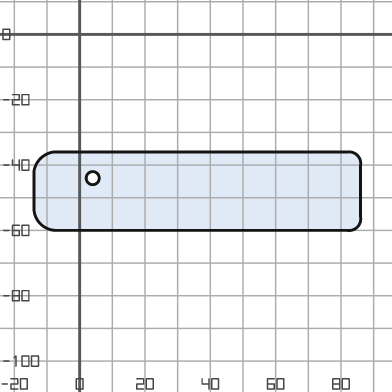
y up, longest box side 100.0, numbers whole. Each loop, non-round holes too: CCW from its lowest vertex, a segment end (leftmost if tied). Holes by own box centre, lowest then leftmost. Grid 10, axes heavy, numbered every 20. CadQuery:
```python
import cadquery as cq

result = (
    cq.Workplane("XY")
    .moveTo(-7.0, -60.0)
    .lineTo(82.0, -60.0)
    .threePointArc((85.0, -59.0), (86.0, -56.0))
    .lineTo(86.0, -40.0)
    .threePointArc((85.0, -37.0), (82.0, -36.0))
    .lineTo(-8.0, -36.0)
    .threePointArc((-12.0, -38.0), (-14.0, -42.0))
    .lineTo(-14.0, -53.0)
    .threePointArc((-12.0, -58.0), (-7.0, -60.0))
    .close()
    .moveTo(4.0, -44.0)
    .circle(2.0)
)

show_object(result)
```